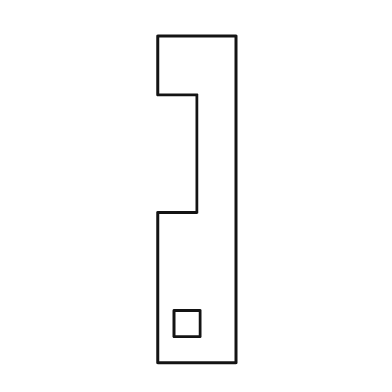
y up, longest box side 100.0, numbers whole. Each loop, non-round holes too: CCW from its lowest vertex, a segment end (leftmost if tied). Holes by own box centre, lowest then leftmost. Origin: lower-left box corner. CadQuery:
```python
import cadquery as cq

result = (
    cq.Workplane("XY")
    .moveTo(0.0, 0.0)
    .lineTo(24.0, 0.0)
    .lineTo(24.0, 100.0)
    .lineTo(0.0, 100.0)
    .lineTo(0.0, 82.0)
    .lineTo(12.0, 82.0)
    .lineTo(12.0, 46.0)
    .lineTo(0.0, 46.0)
    .close()
    .moveTo(5.0, 8.0)
    .lineTo(13.0, 8.0)
    .lineTo(13.0, 16.0)
    .lineTo(5.0, 16.0)
    .close()
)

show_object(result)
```